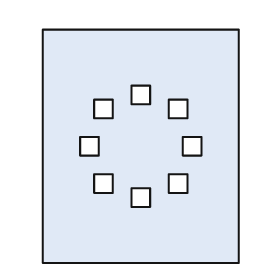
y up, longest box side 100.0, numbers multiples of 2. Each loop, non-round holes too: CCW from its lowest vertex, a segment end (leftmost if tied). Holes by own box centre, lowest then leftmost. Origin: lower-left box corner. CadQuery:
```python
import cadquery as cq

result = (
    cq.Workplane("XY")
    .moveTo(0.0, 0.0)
    .lineTo(84.0, 0.0)
    .lineTo(84.0, 100.0)
    .lineTo(0.0, 100.0)
    .close()
    .moveTo(38.0, 24.0)
    .lineTo(46.0, 24.0)
    .lineTo(46.0, 32.0)
    .lineTo(38.0, 32.0)
    .close()
    .moveTo(22.0, 30.0)
    .lineTo(30.0, 30.0)
    .lineTo(30.0, 38.0)
    .lineTo(22.0, 38.0)
    .close()
    .moveTo(54.0, 30.0)
    .lineTo(62.0, 30.0)
    .lineTo(62.0, 38.0)
    .lineTo(54.0, 38.0)
    .close()
    .moveTo(16.0, 46.0)
    .lineTo(24.0, 46.0)
    .lineTo(24.0, 54.0)
    .lineTo(16.0, 54.0)
    .close()
    .moveTo(60.0, 46.0)
    .lineTo(68.0, 46.0)
    .lineTo(68.0, 54.0)
    .lineTo(60.0, 54.0)
    .close()
    .moveTo(22.0, 62.0)
    .lineTo(30.0, 62.0)
    .lineTo(30.0, 70.0)
    .lineTo(22.0, 70.0)
    .close()
    .moveTo(54.0, 62.0)
    .lineTo(62.0, 62.0)
    .lineTo(62.0, 70.0)
    .lineTo(54.0, 70.0)
    .close()
    .moveTo(38.0, 68.0)
    .lineTo(46.0, 68.0)
    .lineTo(46.0, 76.0)
    .lineTo(38.0, 76.0)
    .close()
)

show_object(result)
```